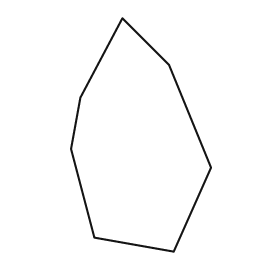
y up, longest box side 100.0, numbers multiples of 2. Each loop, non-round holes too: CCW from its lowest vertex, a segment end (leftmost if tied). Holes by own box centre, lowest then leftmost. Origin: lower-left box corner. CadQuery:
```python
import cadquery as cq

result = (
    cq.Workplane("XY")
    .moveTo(44.0, 0.0)
    .lineTo(60.0, 36.0)
    .lineTo(42.0, 80.0)
    .lineTo(22.0, 100.0)
    .lineTo(4.0, 66.0)
    .lineTo(0.0, 44.0)
    .lineTo(10.0, 6.0)
    .close()
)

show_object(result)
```